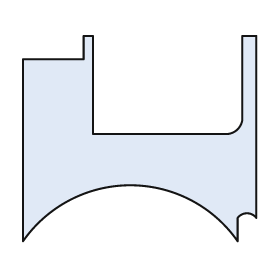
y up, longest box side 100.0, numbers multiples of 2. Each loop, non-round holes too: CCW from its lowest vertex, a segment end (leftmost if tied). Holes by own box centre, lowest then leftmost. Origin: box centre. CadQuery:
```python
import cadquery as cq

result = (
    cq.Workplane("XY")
    .moveTo(-50.0, -44.0)
    .threePointArc((-4.0, -20.0), (42.0, -44.0))
    .lineTo(42.0, -34.0)
    .threePointArc((46.0, -32.0), (50.0, -34.0))
    .lineTo(50.0, 44.0)
    .lineTo(44.0, 44.0)
    .lineTo(44.0, 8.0)
    .threePointArc((42.0, 4.0), (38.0, 2.0))
    .lineTo(-20.0, 2.0)
    .lineTo(-20.0, 44.0)
    .lineTo(-24.0, 44.0)
    .lineTo(-24.0, 34.0)
    .lineTo(-50.0, 34.0)
    .close()
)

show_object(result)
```